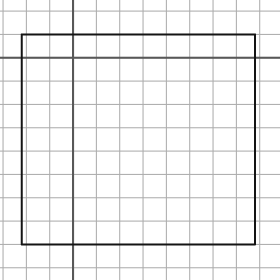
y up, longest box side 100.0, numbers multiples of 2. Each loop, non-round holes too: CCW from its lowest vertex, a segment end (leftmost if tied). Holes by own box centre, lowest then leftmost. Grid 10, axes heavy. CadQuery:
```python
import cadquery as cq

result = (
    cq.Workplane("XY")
    .moveTo(-22.0, -80.0)
    .lineTo(78.0, -80.0)
    .lineTo(78.0, 10.0)
    .lineTo(-22.0, 10.0)
    .close()
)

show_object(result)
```